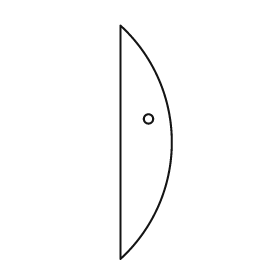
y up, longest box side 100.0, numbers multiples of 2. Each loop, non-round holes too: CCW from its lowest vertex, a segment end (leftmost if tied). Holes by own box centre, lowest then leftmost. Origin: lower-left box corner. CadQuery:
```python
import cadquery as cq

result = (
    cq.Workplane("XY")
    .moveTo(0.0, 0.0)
    .threePointArc((22.0, 50.0), (0.0, 100.0))
    .close()
    .moveTo(12.0, 60.0)
    .circle(2.0)
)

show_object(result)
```